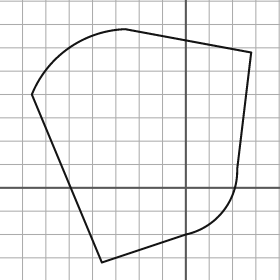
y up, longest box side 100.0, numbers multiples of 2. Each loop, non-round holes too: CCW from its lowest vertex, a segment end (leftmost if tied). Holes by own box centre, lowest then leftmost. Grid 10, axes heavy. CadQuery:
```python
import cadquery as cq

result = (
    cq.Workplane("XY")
    .moveTo(-36.0, -32.0)
    .lineTo(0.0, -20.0)
    .threePointArc((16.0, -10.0), (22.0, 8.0))
    .lineTo(28.0, 58.0)
    .lineTo(-26.0, 68.0)
    .threePointArc((-50.0, 60.0), (-66.0, 40.0))
    .close()
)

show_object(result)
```